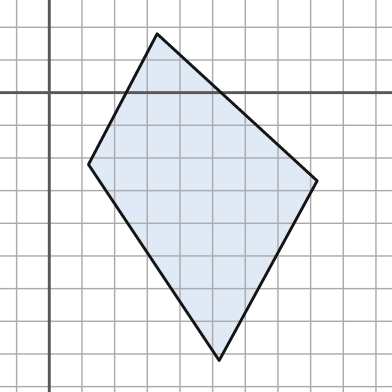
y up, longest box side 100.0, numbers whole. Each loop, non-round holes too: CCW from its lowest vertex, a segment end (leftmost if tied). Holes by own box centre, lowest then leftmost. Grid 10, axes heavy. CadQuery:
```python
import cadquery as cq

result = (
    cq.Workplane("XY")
    .moveTo(52.0, -82.0)
    .lineTo(82.0, -27.0)
    .lineTo(33.0, 18.0)
    .lineTo(12.0, -22.0)
    .close()
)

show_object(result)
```